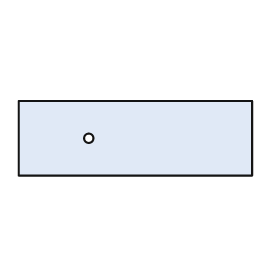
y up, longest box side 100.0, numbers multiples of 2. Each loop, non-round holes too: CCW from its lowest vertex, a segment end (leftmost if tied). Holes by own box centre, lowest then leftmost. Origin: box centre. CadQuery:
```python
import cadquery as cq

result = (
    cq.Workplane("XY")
    .moveTo(-50.0, -16.0)
    .lineTo(50.0, -16.0)
    .lineTo(50.0, 16.0)
    .lineTo(-50.0, 16.0)
    .close()
    .moveTo(-20.0, 0.0)
    .circle(2.0)
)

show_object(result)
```